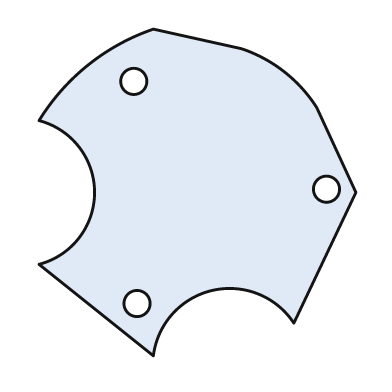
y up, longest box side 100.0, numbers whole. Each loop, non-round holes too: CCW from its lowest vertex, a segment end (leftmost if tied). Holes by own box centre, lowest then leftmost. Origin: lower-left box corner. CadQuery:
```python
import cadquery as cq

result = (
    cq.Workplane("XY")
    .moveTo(35.0, 0.0)
    .threePointArc((53.0, 20.0), (78.0, 10.0))
    .lineTo(97.0, 50.0)
    .lineTo(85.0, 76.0)
    .threePointArc((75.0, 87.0), (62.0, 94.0))
    .lineTo(35.0, 100.0)
    .threePointArc((15.0, 89.0), (0.0, 72.0))
    .threePointArc((17.0, 50.0), (0.0, 28.0))
    .close()
    .moveTo(30.0, 16.0)
    .circle(4.0)
    .moveTo(88.0, 51.0)
    .circle(4.0)
    .moveTo(29.0, 84.0)
    .circle(4.0)
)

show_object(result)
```